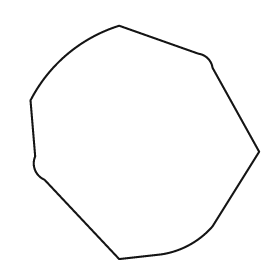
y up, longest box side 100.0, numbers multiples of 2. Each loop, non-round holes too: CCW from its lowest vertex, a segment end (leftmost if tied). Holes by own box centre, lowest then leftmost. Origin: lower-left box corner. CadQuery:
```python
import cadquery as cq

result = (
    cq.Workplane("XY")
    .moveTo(38.0, 0.0)
    .lineTo(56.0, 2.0)
    .threePointArc((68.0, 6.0), (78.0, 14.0))
    .lineTo(98.0, 46.0)
    .lineTo(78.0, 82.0)
    .threePointArc((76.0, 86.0), (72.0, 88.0))
    .lineTo(38.0, 100.0)
    .threePointArc((16.0, 88.0), (0.0, 68.0))
    .lineTo(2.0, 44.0)
    .threePointArc((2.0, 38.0), (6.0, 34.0))
    .close()
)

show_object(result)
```